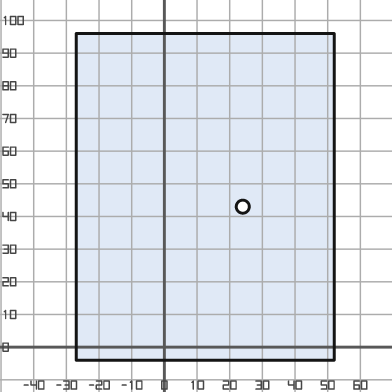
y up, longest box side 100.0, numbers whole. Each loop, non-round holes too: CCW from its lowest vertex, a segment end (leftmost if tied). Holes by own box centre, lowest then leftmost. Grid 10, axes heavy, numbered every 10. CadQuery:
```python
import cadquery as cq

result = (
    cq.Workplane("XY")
    .moveTo(-27.0, -4.0)
    .lineTo(52.0, -4.0)
    .lineTo(52.0, 96.0)
    .lineTo(-27.0, 96.0)
    .close()
    .moveTo(24.0, 43.0)
    .circle(2.0)
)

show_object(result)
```